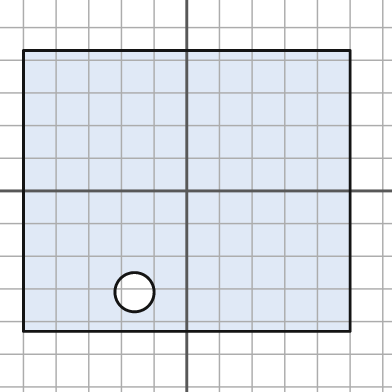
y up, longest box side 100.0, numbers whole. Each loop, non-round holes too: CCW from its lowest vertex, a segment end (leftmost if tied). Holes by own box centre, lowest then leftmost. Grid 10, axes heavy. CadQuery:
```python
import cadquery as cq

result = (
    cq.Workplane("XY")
    .moveTo(-50.0, -43.0)
    .lineTo(50.0, -43.0)
    .lineTo(50.0, 43.0)
    .lineTo(-50.0, 43.0)
    .close()
    .moveTo(-16.0, -31.0)
    .circle(6.0)
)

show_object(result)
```